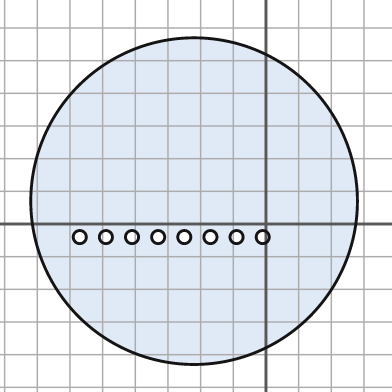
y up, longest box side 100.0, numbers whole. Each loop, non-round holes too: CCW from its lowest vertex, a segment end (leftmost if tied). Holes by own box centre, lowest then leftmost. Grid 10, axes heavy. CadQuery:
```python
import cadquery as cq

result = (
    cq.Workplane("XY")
    .moveTo(-22.0, 7.0)
    .circle(50.0)
    .moveTo(-57.0, -4.0)
    .circle(2.0)
    .moveTo(-49.0, -4.0)
    .circle(2.0)
    .moveTo(-41.0, -4.0)
    .circle(2.0)
    .moveTo(-33.0, -4.0)
    .circle(2.0)
    .moveTo(-25.0, -4.0)
    .circle(2.0)
    .moveTo(-17.0, -4.0)
    .circle(2.0)
    .moveTo(-9.0, -4.0)
    .circle(2.0)
    .moveTo(-1.0, -4.0)
    .circle(2.0)
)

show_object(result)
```